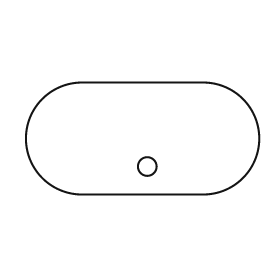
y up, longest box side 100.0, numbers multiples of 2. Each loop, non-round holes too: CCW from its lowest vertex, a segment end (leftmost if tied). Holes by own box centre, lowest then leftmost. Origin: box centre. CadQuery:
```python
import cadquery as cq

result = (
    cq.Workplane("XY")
    .moveTo(-26.0, -24.0)
    .lineTo(26.0, -24.0)
    .threePointArc((50.0, 0.0), (26.0, 24.0))
    .lineTo(-26.0, 24.0)
    .threePointArc((-50.0, 0.0), (-26.0, -24.0))
    .close()
    .moveTo(2.0, -12.0)
    .circle(4.0)
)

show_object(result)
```